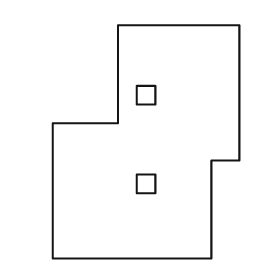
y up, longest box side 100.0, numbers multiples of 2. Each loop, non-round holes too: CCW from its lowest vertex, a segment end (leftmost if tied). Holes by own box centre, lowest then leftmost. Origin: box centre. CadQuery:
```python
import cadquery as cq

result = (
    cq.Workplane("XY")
    .moveTo(-40.0, -50.0)
    .lineTo(28.0, -50.0)
    .lineTo(28.0, -8.0)
    .lineTo(40.0, -8.0)
    .lineTo(40.0, 50.0)
    .lineTo(-12.0, 50.0)
    .lineTo(-12.0, 8.0)
    .lineTo(-40.0, 8.0)
    .close()
    .moveTo(-4.0, -22.0)
    .lineTo(4.0, -22.0)
    .lineTo(4.0, -14.0)
    .lineTo(-4.0, -14.0)
    .close()
    .moveTo(-4.0, 16.0)
    .lineTo(4.0, 16.0)
    .lineTo(4.0, 24.0)
    .lineTo(-4.0, 24.0)
    .close()
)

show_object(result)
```